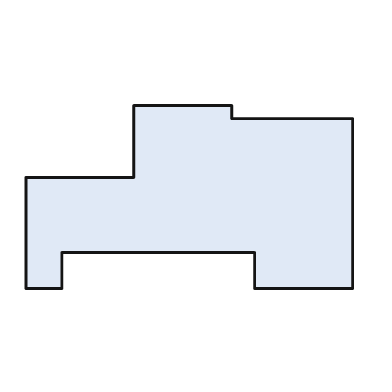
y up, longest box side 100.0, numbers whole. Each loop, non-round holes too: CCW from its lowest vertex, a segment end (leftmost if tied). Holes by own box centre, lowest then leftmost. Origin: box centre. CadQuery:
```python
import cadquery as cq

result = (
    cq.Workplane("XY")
    .moveTo(-50.0, -28.0)
    .lineTo(-39.0, -28.0)
    .lineTo(-39.0, -17.0)
    .lineTo(20.0, -17.0)
    .lineTo(20.0, -28.0)
    .lineTo(50.0, -28.0)
    .lineTo(50.0, 24.0)
    .lineTo(13.0, 24.0)
    .lineTo(13.0, 28.0)
    .lineTo(-17.0, 28.0)
    .lineTo(-17.0, 6.0)
    .lineTo(-50.0, 6.0)
    .close()
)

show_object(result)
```